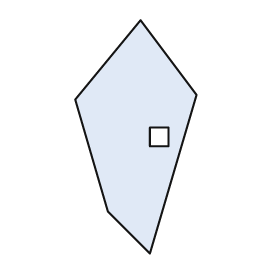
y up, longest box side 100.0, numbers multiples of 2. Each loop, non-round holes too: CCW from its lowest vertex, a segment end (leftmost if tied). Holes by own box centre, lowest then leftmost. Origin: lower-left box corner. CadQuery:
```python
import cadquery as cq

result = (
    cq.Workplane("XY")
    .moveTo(32.0, 0.0)
    .lineTo(52.0, 68.0)
    .lineTo(28.0, 100.0)
    .lineTo(0.0, 66.0)
    .lineTo(14.0, 18.0)
    .close()
    .moveTo(32.0, 46.0)
    .lineTo(40.0, 46.0)
    .lineTo(40.0, 54.0)
    .lineTo(32.0, 54.0)
    .close()
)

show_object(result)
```